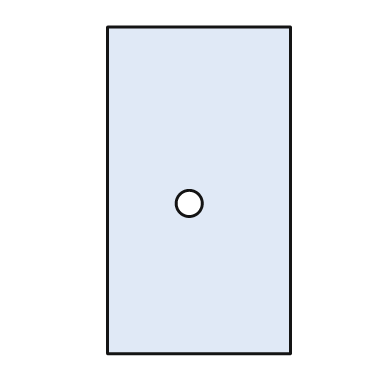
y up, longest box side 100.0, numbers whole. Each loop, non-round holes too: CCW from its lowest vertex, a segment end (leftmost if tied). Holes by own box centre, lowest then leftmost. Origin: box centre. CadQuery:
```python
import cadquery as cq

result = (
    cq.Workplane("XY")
    .moveTo(-28.0, -50.0)
    .lineTo(28.0, -50.0)
    .lineTo(28.0, 50.0)
    .lineTo(-28.0, 50.0)
    .close()
    .moveTo(-3.0, -4.0)
    .circle(4.0)
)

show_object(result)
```